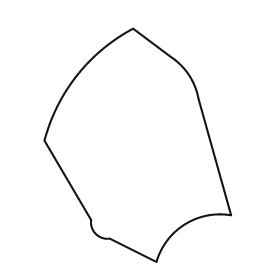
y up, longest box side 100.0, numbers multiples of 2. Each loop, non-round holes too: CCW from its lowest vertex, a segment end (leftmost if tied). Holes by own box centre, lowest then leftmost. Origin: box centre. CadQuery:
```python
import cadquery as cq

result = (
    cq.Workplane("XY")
    .moveTo(8.0, -50.0)
    .threePointArc((20.0, -34.0), (40.0, -30.0))
    .lineTo(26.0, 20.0)
    .threePointArc((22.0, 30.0), (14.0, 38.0))
    .lineTo(-2.0, 50.0)
    .threePointArc((-26.0, 30.0), (-40.0, 2.0))
    .lineTo(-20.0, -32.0)
    .threePointArc((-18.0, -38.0), (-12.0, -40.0))
    .close()
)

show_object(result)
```